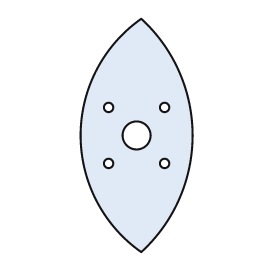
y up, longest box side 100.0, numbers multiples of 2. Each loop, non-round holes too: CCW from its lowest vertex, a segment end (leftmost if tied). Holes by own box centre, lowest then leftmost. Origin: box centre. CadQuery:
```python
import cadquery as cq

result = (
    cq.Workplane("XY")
    .moveTo(2.0, -50.0)
    .threePointArc((24.0, 0.0), (2.0, 50.0))
    .threePointArc((-24.0, 0.0), (2.0, -50.0))
    .close()
    .moveTo(-12.0, -12.0)
    .circle(2.0)
    .moveTo(12.0, -12.0)
    .circle(2.0)
    .moveTo(0.0, 0.0)
    .circle(6.0)
    .moveTo(-12.0, 12.0)
    .circle(2.0)
    .moveTo(12.0, 12.0)
    .circle(2.0)
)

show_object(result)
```